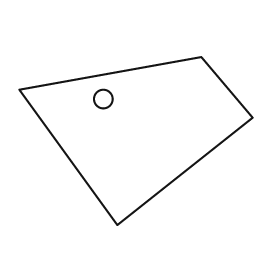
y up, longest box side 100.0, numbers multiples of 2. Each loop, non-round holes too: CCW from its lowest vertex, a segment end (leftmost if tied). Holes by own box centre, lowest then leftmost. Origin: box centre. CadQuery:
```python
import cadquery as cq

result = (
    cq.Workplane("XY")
    .moveTo(-8.0, -36.0)
    .lineTo(50.0, 10.0)
    .lineTo(28.0, 36.0)
    .lineTo(-50.0, 22.0)
    .close()
    .moveTo(-14.0, 18.0)
    .circle(4.0)
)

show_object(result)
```